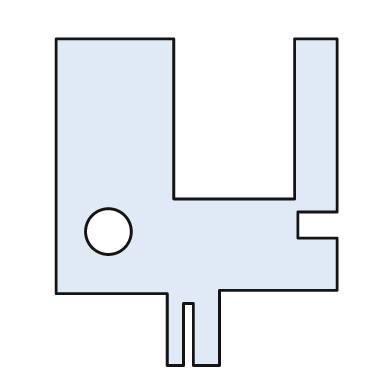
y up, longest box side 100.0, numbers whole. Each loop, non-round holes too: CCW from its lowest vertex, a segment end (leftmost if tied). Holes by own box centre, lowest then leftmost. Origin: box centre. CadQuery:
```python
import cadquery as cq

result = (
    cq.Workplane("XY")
    .moveTo(-9.0, -50.0)
    .lineTo(-4.0, -50.0)
    .lineTo(-4.0, -31.0)
    .lineTo(-1.0, -31.0)
    .lineTo(-1.0, -50.0)
    .lineTo(7.0, -50.0)
    .lineTo(7.0, -27.0)
    .lineTo(43.0, -27.0)
    .lineTo(43.0, -11.0)
    .lineTo(31.0, -11.0)
    .lineTo(31.0, -3.0)
    .lineTo(43.0, -3.0)
    .lineTo(43.0, 50.0)
    .lineTo(30.0, 50.0)
    .lineTo(30.0, 1.0)
    .lineTo(-7.0, 1.0)
    .lineTo(-7.0, 50.0)
    .lineTo(-43.0, 50.0)
    .lineTo(-43.0, -28.0)
    .lineTo(-9.0, -28.0)
    .close()
    .moveTo(-27.0, -9.0)
    .circle(7.0)
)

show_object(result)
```